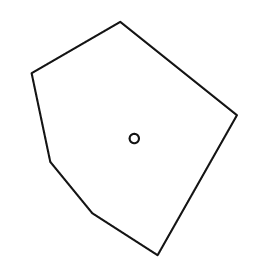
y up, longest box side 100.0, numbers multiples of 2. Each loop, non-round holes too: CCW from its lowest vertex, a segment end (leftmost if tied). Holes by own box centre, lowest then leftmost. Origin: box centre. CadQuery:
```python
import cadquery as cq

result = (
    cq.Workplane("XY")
    .moveTo(10.0, -50.0)
    .lineTo(44.0, 10.0)
    .lineTo(-6.0, 50.0)
    .lineTo(-44.0, 28.0)
    .lineTo(-36.0, -10.0)
    .lineTo(-18.0, -32.0)
    .close()
    .moveTo(0.0, 0.0)
    .circle(2.0)
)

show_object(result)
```